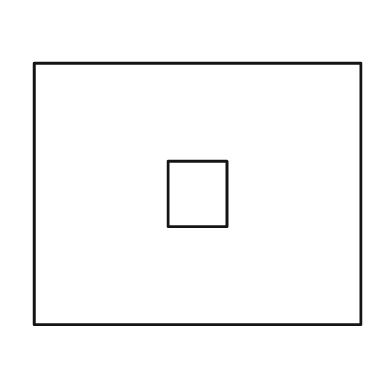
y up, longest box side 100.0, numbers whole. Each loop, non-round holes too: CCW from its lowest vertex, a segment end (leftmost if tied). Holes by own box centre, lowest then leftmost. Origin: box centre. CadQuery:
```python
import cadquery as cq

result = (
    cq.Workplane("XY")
    .moveTo(-50.0, -40.0)
    .lineTo(50.0, -40.0)
    .lineTo(50.0, 40.0)
    .lineTo(-50.0, 40.0)
    .close()
    .moveTo(-9.0, -10.0)
    .lineTo(9.0, -10.0)
    .lineTo(9.0, 10.0)
    .lineTo(-9.0, 10.0)
    .close()
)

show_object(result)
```